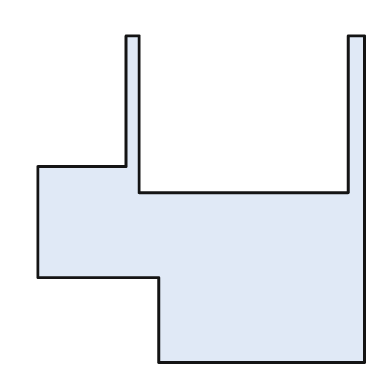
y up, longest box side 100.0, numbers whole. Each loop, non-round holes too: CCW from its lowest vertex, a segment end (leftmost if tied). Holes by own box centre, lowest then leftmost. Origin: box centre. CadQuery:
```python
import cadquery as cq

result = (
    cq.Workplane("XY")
    .moveTo(-13.0, -50.0)
    .lineTo(50.0, -50.0)
    .lineTo(50.0, 50.0)
    .lineTo(45.0, 50.0)
    .lineTo(45.0, 2.0)
    .lineTo(-19.0, 2.0)
    .lineTo(-19.0, 50.0)
    .lineTo(-23.0, 50.0)
    .lineTo(-23.0, 10.0)
    .lineTo(-50.0, 10.0)
    .lineTo(-50.0, -24.0)
    .lineTo(-13.0, -24.0)
    .close()
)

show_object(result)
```